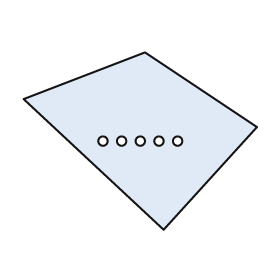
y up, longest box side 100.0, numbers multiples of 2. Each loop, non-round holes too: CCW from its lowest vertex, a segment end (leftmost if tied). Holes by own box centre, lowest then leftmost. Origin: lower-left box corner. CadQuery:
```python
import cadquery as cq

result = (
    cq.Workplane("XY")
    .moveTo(60.0, 0.0)
    .lineTo(100.0, 44.0)
    .lineTo(52.0, 76.0)
    .lineTo(0.0, 56.0)
    .close()
    .moveTo(34.0, 38.0)
    .circle(2.0)
    .moveTo(42.0, 38.0)
    .circle(2.0)
    .moveTo(50.0, 38.0)
    .circle(2.0)
    .moveTo(58.0, 38.0)
    .circle(2.0)
    .moveTo(66.0, 38.0)
    .circle(2.0)
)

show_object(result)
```